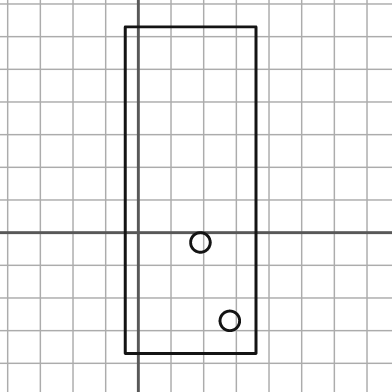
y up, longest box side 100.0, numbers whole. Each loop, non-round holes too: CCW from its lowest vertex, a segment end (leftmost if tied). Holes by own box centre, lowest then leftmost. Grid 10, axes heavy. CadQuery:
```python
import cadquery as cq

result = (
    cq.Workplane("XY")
    .moveTo(-4.0, -37.0)
    .lineTo(36.0, -37.0)
    .lineTo(36.0, 63.0)
    .lineTo(-4.0, 63.0)
    .close()
    .moveTo(28.0, -27.0)
    .circle(3.0)
    .moveTo(19.0, -3.0)
    .circle(3.0)
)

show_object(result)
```